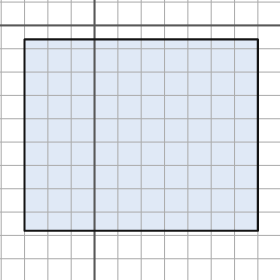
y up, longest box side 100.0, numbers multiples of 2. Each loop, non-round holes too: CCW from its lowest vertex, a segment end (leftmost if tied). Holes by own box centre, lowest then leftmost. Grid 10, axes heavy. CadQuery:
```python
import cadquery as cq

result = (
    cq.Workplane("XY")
    .moveTo(-30.0, -88.0)
    .lineTo(70.0, -88.0)
    .lineTo(70.0, -6.0)
    .lineTo(-30.0, -6.0)
    .close()
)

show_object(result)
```